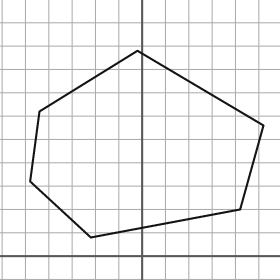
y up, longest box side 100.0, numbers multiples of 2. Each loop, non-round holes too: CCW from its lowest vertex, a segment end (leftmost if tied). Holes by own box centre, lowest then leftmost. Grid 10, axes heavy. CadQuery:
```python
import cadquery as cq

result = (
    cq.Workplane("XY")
    .moveTo(-22.0, 8.0)
    .lineTo(42.0, 20.0)
    .lineTo(52.0, 56.0)
    .lineTo(-2.0, 88.0)
    .lineTo(-44.0, 62.0)
    .lineTo(-48.0, 32.0)
    .close()
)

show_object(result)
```